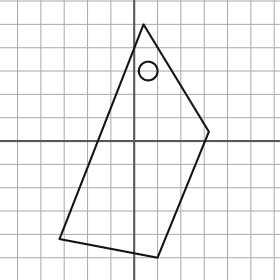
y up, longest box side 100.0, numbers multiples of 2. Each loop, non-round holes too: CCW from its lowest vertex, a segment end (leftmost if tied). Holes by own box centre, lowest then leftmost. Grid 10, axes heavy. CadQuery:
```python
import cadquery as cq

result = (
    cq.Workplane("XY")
    .moveTo(10.0, -50.0)
    .lineTo(32.0, 4.0)
    .lineTo(4.0, 50.0)
    .lineTo(-32.0, -42.0)
    .close()
    .moveTo(6.0, 30.0)
    .circle(4.0)
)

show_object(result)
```